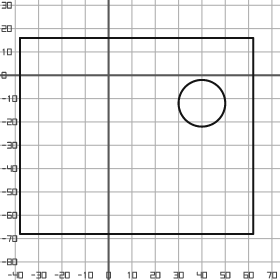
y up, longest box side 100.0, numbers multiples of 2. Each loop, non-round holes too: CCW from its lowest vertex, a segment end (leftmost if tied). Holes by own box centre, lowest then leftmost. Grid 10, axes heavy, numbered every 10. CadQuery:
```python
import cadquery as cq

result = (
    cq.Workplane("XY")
    .moveTo(-38.0, -68.0)
    .lineTo(62.0, -68.0)
    .lineTo(62.0, 16.0)
    .lineTo(-38.0, 16.0)
    .close()
    .moveTo(40.0, -12.0)
    .circle(10.0)
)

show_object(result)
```